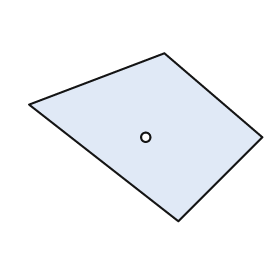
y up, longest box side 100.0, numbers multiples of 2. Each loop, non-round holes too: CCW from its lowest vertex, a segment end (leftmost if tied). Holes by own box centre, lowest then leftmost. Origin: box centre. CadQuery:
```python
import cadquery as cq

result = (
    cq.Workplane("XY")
    .moveTo(14.0, -36.0)
    .lineTo(50.0, 0.0)
    .lineTo(8.0, 36.0)
    .lineTo(-50.0, 14.0)
    .close()
    .moveTo(0.0, 0.0)
    .circle(2.0)
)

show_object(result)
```